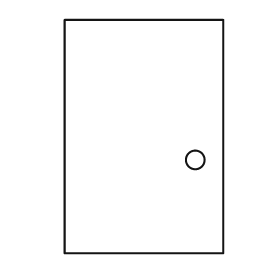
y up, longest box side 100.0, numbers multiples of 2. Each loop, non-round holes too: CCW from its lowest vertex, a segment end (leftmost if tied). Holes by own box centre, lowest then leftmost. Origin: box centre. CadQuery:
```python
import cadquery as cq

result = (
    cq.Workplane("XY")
    .moveTo(-34.0, -50.0)
    .lineTo(34.0, -50.0)
    .lineTo(34.0, 50.0)
    .lineTo(-34.0, 50.0)
    .close()
    .moveTo(22.0, -10.0)
    .circle(4.0)
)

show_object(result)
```